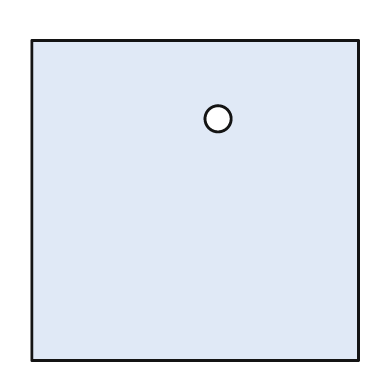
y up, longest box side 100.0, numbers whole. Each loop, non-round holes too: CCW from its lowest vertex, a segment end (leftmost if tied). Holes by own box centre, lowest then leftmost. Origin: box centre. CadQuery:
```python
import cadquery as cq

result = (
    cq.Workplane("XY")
    .moveTo(-50.0, -49.0)
    .lineTo(50.0, -49.0)
    .lineTo(50.0, 49.0)
    .lineTo(-50.0, 49.0)
    .close()
    .moveTo(7.0, 25.0)
    .circle(4.0)
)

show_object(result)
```